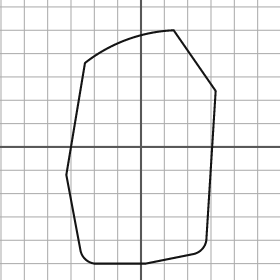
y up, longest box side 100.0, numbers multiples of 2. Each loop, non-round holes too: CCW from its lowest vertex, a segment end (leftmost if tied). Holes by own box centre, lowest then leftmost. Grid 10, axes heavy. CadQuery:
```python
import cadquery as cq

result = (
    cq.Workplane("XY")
    .moveTo(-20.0, -50.0)
    .lineTo(2.0, -50.0)
    .lineTo(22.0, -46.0)
    .threePointArc((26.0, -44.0), (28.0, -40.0))
    .lineTo(32.0, 24.0)
    .lineTo(14.0, 50.0)
    .threePointArc((-6.0, 46.0), (-24.0, 36.0))
    .lineTo(-32.0, -12.0)
    .lineTo(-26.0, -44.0)
    .threePointArc((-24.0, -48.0), (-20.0, -50.0))
    .close()
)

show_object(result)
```